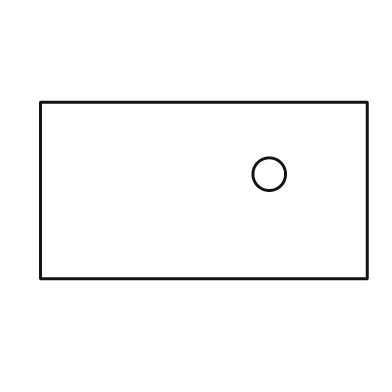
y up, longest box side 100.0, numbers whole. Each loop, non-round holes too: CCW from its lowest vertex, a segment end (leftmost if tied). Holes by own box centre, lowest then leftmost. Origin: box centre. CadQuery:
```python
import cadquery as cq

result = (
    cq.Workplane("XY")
    .moveTo(-50.0, -27.0)
    .lineTo(50.0, -27.0)
    .lineTo(50.0, 27.0)
    .lineTo(-50.0, 27.0)
    .close()
    .moveTo(20.0, 5.0)
    .circle(5.0)
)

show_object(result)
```